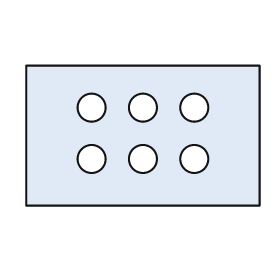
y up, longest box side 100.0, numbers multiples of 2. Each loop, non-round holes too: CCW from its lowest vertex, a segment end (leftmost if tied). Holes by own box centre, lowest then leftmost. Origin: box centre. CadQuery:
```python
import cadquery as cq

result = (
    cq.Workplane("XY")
    .moveTo(-50.0, -30.0)
    .lineTo(50.0, -30.0)
    .lineTo(50.0, 30.0)
    .lineTo(-50.0, 30.0)
    .close()
    .moveTo(-22.0, -10.0)
    .circle(6.0)
    .moveTo(0.0, -10.0)
    .circle(6.0)
    .moveTo(22.0, -10.0)
    .circle(6.0)
    .moveTo(-22.0, 12.0)
    .circle(6.0)
    .moveTo(0.0, 12.0)
    .circle(6.0)
    .moveTo(22.0, 12.0)
    .circle(6.0)
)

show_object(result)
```